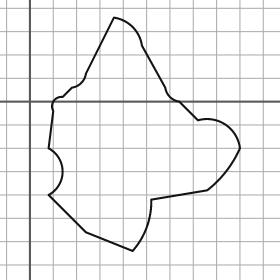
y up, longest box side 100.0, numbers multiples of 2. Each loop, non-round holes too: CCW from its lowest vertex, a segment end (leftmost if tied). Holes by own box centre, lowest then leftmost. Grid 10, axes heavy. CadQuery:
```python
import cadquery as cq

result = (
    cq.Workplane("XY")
    .moveTo(44.0, -64.0)
    .threePointArc((50.0, -54.0), (52.0, -42.0))
    .lineTo(76.0, -38.0)
    .threePointArc((84.0, -30.0), (90.0, -20.0))
    .threePointArc((84.0, -10.0), (72.0, -8.0))
    .lineTo(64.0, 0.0)
    .threePointArc((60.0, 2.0), (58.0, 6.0))
    .lineTo(48.0, 24.0)
    .threePointArc((44.0, 32.0), (36.0, 36.0))
    .lineTo(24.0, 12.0)
    .threePointArc((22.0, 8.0), (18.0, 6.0))
    .lineTo(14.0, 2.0)
    .threePointArc((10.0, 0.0), (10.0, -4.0))
    .lineTo(8.0, -20.0)
    .threePointArc((14.0, -30.0), (8.0, -40.0))
    .lineTo(24.0, -56.0)
    .close()
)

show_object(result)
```